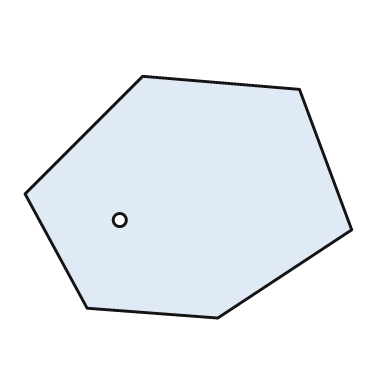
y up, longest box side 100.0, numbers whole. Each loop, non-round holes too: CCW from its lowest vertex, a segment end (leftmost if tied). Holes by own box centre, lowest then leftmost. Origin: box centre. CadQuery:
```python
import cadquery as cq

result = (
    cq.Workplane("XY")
    .moveTo(9.0, -37.0)
    .lineTo(50.0, -10.0)
    .lineTo(34.0, 33.0)
    .lineTo(-14.0, 37.0)
    .lineTo(-50.0, 1.0)
    .lineTo(-31.0, -34.0)
    .close()
    .moveTo(-21.0, -7.0)
    .circle(2.0)
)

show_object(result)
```